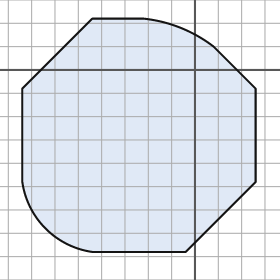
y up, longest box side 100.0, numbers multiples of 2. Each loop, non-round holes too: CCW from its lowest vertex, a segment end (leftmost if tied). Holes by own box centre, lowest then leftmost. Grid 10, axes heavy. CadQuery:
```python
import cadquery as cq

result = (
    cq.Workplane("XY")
    .moveTo(-44.0, -78.0)
    .lineTo(-4.0, -78.0)
    .lineTo(26.0, -48.0)
    .lineTo(26.0, -8.0)
    .lineTo(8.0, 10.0)
    .threePointArc((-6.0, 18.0), (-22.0, 22.0))
    .lineTo(-44.0, 22.0)
    .lineTo(-74.0, -8.0)
    .lineTo(-74.0, -48.0)
    .threePointArc((-64.0, -68.0), (-44.0, -78.0))
    .close()
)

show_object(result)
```